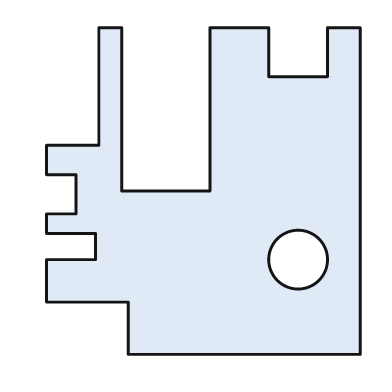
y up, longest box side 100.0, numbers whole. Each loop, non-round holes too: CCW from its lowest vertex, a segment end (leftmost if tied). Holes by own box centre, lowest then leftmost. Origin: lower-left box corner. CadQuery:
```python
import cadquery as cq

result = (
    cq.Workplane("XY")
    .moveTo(25.0, 0.0)
    .lineTo(96.0, 0.0)
    .lineTo(96.0, 100.0)
    .lineTo(86.0, 100.0)
    .lineTo(86.0, 85.0)
    .lineTo(68.0, 85.0)
    .lineTo(68.0, 100.0)
    .lineTo(50.0, 100.0)
    .lineTo(50.0, 50.0)
    .lineTo(23.0, 50.0)
    .lineTo(23.0, 100.0)
    .lineTo(16.0, 100.0)
    .lineTo(16.0, 64.0)
    .lineTo(0.0, 64.0)
    .lineTo(0.0, 55.0)
    .lineTo(9.0, 55.0)
    .lineTo(9.0, 43.0)
    .lineTo(0.0, 43.0)
    .lineTo(0.0, 37.0)
    .lineTo(15.0, 37.0)
    .lineTo(15.0, 29.0)
    .lineTo(0.0, 29.0)
    .lineTo(0.0, 16.0)
    .lineTo(25.0, 16.0)
    .close()
    .moveTo(77.0, 29.0)
    .circle(9.0)
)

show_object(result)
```